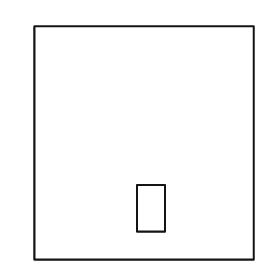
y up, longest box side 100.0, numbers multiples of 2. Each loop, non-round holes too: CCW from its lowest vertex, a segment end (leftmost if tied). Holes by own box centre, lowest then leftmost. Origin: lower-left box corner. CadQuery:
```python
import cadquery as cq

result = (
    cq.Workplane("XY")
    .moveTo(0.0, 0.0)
    .lineTo(94.0, 0.0)
    .lineTo(94.0, 100.0)
    .lineTo(0.0, 100.0)
    .close()
    .moveTo(44.0, 12.0)
    .lineTo(56.0, 12.0)
    .lineTo(56.0, 32.0)
    .lineTo(44.0, 32.0)
    .close()
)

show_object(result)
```